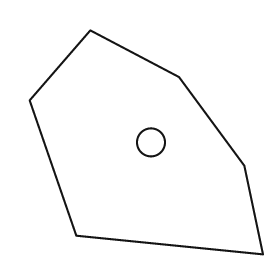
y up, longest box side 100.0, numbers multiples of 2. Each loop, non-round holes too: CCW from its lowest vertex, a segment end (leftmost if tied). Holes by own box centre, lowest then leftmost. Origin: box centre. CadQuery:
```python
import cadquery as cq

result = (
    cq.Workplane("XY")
    .moveTo(50.0, -48.0)
    .lineTo(42.0, -10.0)
    .lineTo(14.0, 28.0)
    .lineTo(-24.0, 48.0)
    .lineTo(-50.0, 18.0)
    .lineTo(-30.0, -40.0)
    .close()
    .moveTo(2.0, 0.0)
    .circle(6.0)
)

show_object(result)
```